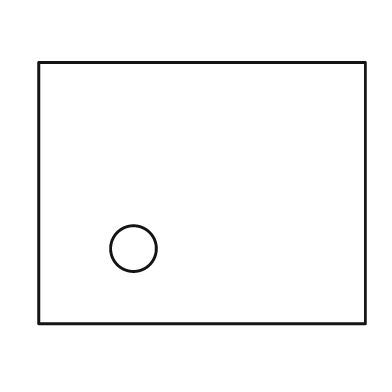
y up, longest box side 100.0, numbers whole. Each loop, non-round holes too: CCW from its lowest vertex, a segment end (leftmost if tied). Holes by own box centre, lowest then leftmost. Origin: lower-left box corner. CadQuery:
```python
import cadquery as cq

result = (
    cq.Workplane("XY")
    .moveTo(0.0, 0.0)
    .lineTo(100.0, 0.0)
    .lineTo(100.0, 80.0)
    .lineTo(0.0, 80.0)
    .close()
    .moveTo(29.0, 23.0)
    .circle(7.0)
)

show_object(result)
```